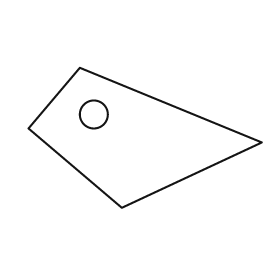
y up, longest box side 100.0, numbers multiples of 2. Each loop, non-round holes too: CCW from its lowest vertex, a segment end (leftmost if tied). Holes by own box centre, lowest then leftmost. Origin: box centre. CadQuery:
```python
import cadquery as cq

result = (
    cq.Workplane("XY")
    .moveTo(-10.0, -30.0)
    .lineTo(50.0, -2.0)
    .lineTo(-28.0, 30.0)
    .lineTo(-50.0, 4.0)
    .close()
    .moveTo(-22.0, 10.0)
    .circle(6.0)
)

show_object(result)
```